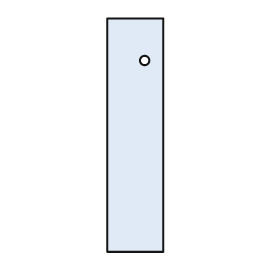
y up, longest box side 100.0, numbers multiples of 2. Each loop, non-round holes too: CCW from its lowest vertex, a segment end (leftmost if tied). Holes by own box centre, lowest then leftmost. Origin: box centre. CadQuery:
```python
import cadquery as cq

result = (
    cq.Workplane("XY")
    .moveTo(-12.0, -50.0)
    .lineTo(12.0, -50.0)
    .lineTo(12.0, 50.0)
    .lineTo(-12.0, 50.0)
    .close()
    .moveTo(4.0, 32.0)
    .circle(2.0)
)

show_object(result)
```